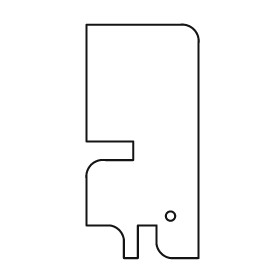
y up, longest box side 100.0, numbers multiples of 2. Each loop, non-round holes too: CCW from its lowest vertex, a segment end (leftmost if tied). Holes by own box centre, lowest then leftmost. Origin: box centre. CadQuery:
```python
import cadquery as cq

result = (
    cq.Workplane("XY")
    .moveTo(-8.0, -50.0)
    .lineTo(-2.0, -50.0)
    .lineTo(-2.0, -36.0)
    .lineTo(6.0, -36.0)
    .lineTo(6.0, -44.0)
    .threePointArc((8.0, -48.0), (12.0, -50.0))
    .lineTo(24.0, -50.0)
    .lineTo(24.0, 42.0)
    .threePointArc((22.0, 48.0), (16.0, 50.0))
    .lineTo(-24.0, 50.0)
    .lineTo(-24.0, 0.0)
    .lineTo(-4.0, 0.0)
    .lineTo(-4.0, -8.0)
    .lineTo(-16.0, -8.0)
    .threePointArc((-22.0, -10.0), (-24.0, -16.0))
    .lineTo(-24.0, -36.0)
    .lineTo(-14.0, -36.0)
    .threePointArc((-10.0, -38.0), (-8.0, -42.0))
    .close()
    .moveTo(12.0, -32.0)
    .circle(2.0)
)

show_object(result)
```